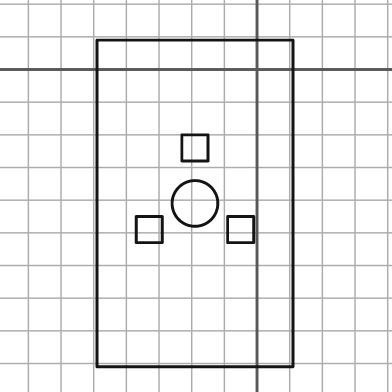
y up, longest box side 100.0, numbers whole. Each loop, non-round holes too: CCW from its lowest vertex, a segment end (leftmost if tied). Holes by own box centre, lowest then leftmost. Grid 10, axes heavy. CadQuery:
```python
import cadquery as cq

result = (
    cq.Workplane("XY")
    .moveTo(-49.0, -91.0)
    .lineTo(11.0, -91.0)
    .lineTo(11.0, 9.0)
    .lineTo(-49.0, 9.0)
    .close()
    .moveTo(-37.0, -53.0)
    .lineTo(-29.0, -53.0)
    .lineTo(-29.0, -45.0)
    .lineTo(-37.0, -45.0)
    .close()
    .moveTo(-9.0, -53.0)
    .lineTo(-1.0, -53.0)
    .lineTo(-1.0, -45.0)
    .lineTo(-9.0, -45.0)
    .close()
    .moveTo(-19.0, -41.0)
    .circle(7.0)
    .moveTo(-23.0, -28.0)
    .lineTo(-15.0, -28.0)
    .lineTo(-15.0, -20.0)
    .lineTo(-23.0, -20.0)
    .close()
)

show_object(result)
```